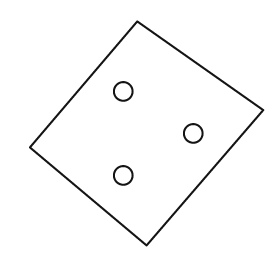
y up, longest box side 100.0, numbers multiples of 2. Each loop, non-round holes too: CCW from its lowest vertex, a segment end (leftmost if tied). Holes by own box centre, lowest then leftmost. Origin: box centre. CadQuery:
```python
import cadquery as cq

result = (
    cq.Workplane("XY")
    .moveTo(0.0, -48.0)
    .lineTo(50.0, 10.0)
    .lineTo(-4.0, 48.0)
    .lineTo(-50.0, -6.0)
    .close()
    .moveTo(-10.0, -18.0)
    .circle(4.0)
    .moveTo(20.0, 0.0)
    .circle(4.0)
    .moveTo(-10.0, 18.0)
    .circle(4.0)
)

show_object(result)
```